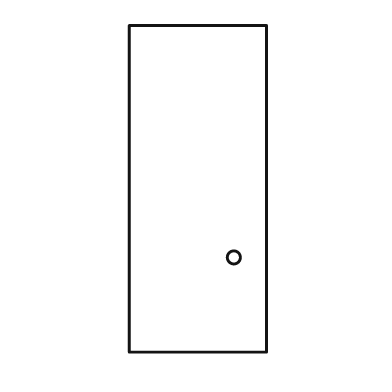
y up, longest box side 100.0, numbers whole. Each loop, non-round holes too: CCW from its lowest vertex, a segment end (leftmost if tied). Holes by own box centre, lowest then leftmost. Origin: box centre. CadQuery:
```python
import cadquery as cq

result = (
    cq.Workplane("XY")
    .moveTo(-21.0, -50.0)
    .lineTo(21.0, -50.0)
    .lineTo(21.0, 50.0)
    .lineTo(-21.0, 50.0)
    .close()
    .moveTo(11.0, -21.0)
    .circle(2.0)
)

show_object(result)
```